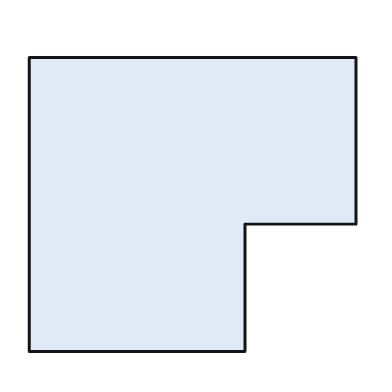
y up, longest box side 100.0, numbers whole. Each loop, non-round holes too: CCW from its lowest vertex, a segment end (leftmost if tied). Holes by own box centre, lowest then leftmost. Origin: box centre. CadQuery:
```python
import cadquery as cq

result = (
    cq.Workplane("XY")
    .moveTo(-50.0, -45.0)
    .lineTo(16.0, -45.0)
    .lineTo(16.0, -6.0)
    .lineTo(50.0, -6.0)
    .lineTo(50.0, 45.0)
    .lineTo(-50.0, 45.0)
    .close()
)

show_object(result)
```